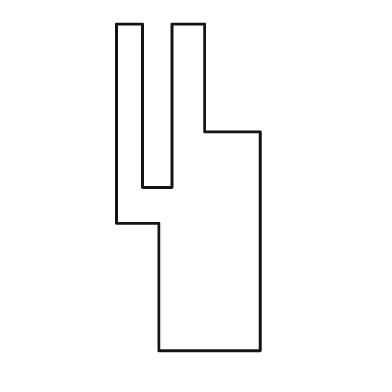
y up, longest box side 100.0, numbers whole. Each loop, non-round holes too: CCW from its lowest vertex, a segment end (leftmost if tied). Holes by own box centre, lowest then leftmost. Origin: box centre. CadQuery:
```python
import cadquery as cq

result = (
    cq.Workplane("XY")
    .moveTo(-9.0, -50.0)
    .lineTo(22.0, -50.0)
    .lineTo(22.0, 17.0)
    .lineTo(5.0, 17.0)
    .lineTo(5.0, 50.0)
    .lineTo(-5.0, 50.0)
    .lineTo(-5.0, 0.0)
    .lineTo(-14.0, 0.0)
    .lineTo(-14.0, 50.0)
    .lineTo(-22.0, 50.0)
    .lineTo(-22.0, -11.0)
    .lineTo(-9.0, -11.0)
    .close()
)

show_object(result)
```